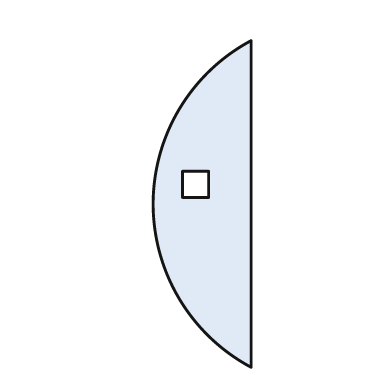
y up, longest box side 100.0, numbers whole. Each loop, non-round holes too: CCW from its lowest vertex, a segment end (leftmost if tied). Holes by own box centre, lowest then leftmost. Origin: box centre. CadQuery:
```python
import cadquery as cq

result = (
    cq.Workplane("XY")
    .moveTo(15.0, -50.0)
    .lineTo(15.0, 50.0)
    .threePointArc((-15.0, 0.0), (15.0, -50.0))
    .close()
    .moveTo(-6.0, 2.0)
    .lineTo(2.0, 2.0)
    .lineTo(2.0, 10.0)
    .lineTo(-6.0, 10.0)
    .close()
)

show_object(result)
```